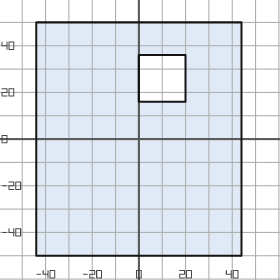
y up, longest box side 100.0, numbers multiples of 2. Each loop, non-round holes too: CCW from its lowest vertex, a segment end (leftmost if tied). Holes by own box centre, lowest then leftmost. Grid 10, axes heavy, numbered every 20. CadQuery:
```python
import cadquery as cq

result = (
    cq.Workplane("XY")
    .moveTo(-44.0, -50.0)
    .lineTo(44.0, -50.0)
    .lineTo(44.0, 50.0)
    .lineTo(-44.0, 50.0)
    .close()
    .moveTo(0.0, 16.0)
    .lineTo(20.0, 16.0)
    .lineTo(20.0, 36.0)
    .lineTo(0.0, 36.0)
    .close()
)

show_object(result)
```